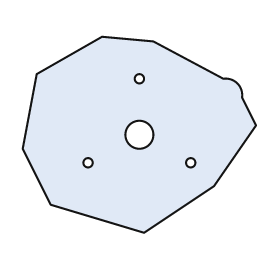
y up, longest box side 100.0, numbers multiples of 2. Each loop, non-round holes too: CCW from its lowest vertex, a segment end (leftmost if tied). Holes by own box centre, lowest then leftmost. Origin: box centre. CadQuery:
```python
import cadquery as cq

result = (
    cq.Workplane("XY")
    .moveTo(2.0, -42.0)
    .lineTo(32.0, -22.0)
    .lineTo(50.0, 4.0)
    .lineTo(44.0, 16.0)
    .threePointArc((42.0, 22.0), (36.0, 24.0))
    .lineTo(6.0, 40.0)
    .lineTo(-16.0, 42.0)
    .lineTo(-44.0, 26.0)
    .lineTo(-50.0, -6.0)
    .lineTo(-38.0, -30.0)
    .close()
    .moveTo(-22.0, -12.0)
    .circle(2.0)
    .moveTo(22.0, -12.0)
    .circle(2.0)
    .moveTo(0.0, 0.0)
    .circle(6.0)
    .moveTo(0.0, 24.0)
    .circle(2.0)
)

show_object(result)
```